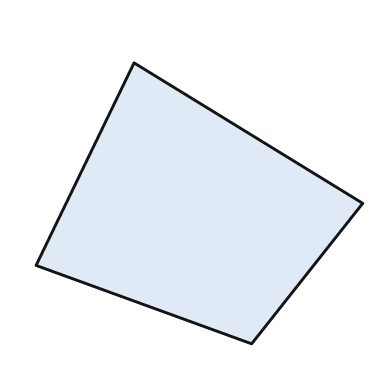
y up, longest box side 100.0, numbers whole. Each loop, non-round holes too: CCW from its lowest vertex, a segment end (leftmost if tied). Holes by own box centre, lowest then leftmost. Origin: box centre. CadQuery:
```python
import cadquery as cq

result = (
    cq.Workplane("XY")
    .moveTo(16.0, -43.0)
    .lineTo(50.0, 0.0)
    .lineTo(-20.0, 43.0)
    .lineTo(-50.0, -19.0)
    .close()
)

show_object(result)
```